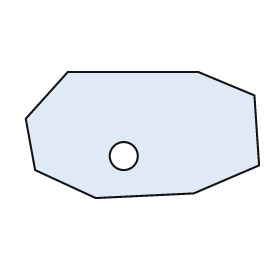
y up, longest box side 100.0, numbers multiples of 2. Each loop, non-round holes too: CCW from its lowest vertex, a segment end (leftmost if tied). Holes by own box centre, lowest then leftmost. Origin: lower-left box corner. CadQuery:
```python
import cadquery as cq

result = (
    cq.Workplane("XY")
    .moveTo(30.0, 0.0)
    .lineTo(72.0, 2.0)
    .lineTo(100.0, 14.0)
    .lineTo(98.0, 44.0)
    .lineTo(74.0, 54.0)
    .lineTo(18.0, 54.0)
    .lineTo(0.0, 34.0)
    .lineTo(4.0, 12.0)
    .close()
    .moveTo(42.0, 18.0)
    .circle(6.0)
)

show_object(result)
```